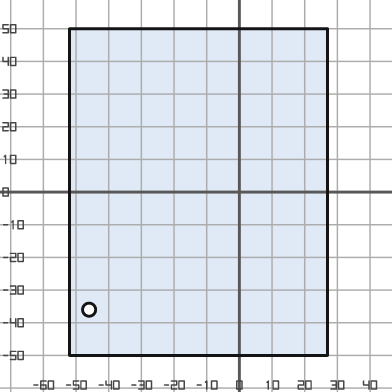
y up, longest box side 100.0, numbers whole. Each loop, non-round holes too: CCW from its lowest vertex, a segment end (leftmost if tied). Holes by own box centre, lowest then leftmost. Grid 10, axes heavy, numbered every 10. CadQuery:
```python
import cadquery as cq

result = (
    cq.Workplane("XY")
    .moveTo(-52.0, -50.0)
    .lineTo(27.0, -50.0)
    .lineTo(27.0, 50.0)
    .lineTo(-52.0, 50.0)
    .close()
    .moveTo(-46.0, -36.0)
    .circle(2.0)
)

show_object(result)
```